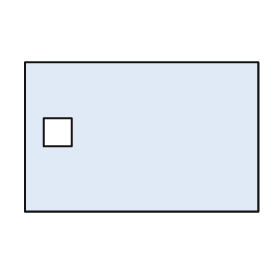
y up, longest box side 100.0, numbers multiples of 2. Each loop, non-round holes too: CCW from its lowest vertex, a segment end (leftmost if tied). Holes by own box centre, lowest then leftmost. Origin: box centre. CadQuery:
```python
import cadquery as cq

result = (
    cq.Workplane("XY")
    .moveTo(-50.0, -32.0)
    .lineTo(50.0, -32.0)
    .lineTo(50.0, 32.0)
    .lineTo(-50.0, 32.0)
    .close()
    .moveTo(-42.0, -4.0)
    .lineTo(-30.0, -4.0)
    .lineTo(-30.0, 8.0)
    .lineTo(-42.0, 8.0)
    .close()
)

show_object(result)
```